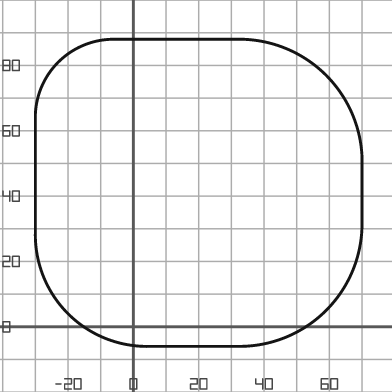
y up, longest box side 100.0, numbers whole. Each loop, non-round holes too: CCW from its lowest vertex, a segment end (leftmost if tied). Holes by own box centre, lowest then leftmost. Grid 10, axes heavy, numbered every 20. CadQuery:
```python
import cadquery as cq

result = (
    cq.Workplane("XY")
    .moveTo(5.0, -6.0)
    .lineTo(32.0, -6.0)
    .threePointArc((59.0, 5.0), (70.0, 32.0))
    .lineTo(70.0, 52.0)
    .threePointArc((59.0, 77.0), (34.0, 88.0))
    .lineTo(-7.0, 88.0)
    .threePointArc((-23.0, 81.0), (-30.0, 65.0))
    .lineTo(-30.0, 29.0)
    .threePointArc((-20.0, 4.0), (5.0, -6.0))
    .close()
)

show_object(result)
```